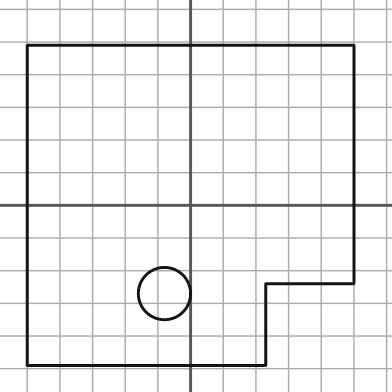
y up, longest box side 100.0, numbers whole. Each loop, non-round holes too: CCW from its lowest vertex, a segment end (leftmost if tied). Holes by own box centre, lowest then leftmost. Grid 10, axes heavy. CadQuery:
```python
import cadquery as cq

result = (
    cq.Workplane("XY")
    .moveTo(-50.0, -49.0)
    .lineTo(23.0, -49.0)
    .lineTo(23.0, -24.0)
    .lineTo(50.0, -24.0)
    .lineTo(50.0, 49.0)
    .lineTo(-50.0, 49.0)
    .close()
    .moveTo(-8.0, -27.0)
    .circle(8.0)
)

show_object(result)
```